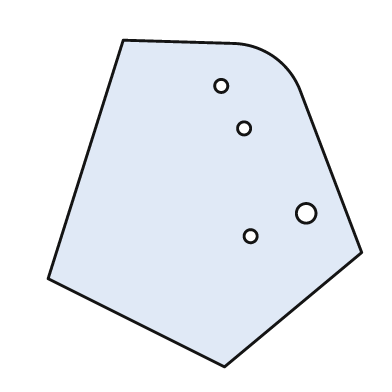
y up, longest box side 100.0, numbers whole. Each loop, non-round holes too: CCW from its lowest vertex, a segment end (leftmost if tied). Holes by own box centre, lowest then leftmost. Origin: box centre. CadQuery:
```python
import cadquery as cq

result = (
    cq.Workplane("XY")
    .moveTo(6.0, -50.0)
    .lineTo(48.0, -15.0)
    .lineTo(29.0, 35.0)
    .threePointArc((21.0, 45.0), (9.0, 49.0))
    .lineTo(-25.0, 50.0)
    .lineTo(-48.0, -23.0)
    .close()
    .moveTo(14.0, -10.0)
    .circle(2.0)
    .moveTo(31.0, -3.0)
    .circle(3.0)
    .moveTo(12.0, 23.0)
    .circle(2.0)
    .moveTo(5.0, 36.0)
    .circle(2.0)
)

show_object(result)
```